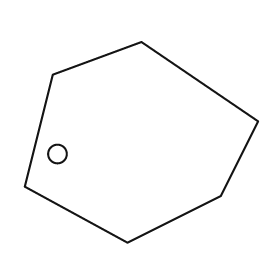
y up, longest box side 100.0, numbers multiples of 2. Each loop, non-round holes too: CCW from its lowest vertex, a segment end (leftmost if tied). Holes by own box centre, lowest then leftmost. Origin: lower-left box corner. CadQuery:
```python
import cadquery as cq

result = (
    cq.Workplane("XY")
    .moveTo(44.0, 0.0)
    .lineTo(84.0, 20.0)
    .lineTo(100.0, 52.0)
    .lineTo(50.0, 86.0)
    .lineTo(12.0, 72.0)
    .lineTo(0.0, 24.0)
    .close()
    .moveTo(14.0, 38.0)
    .circle(4.0)
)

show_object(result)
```